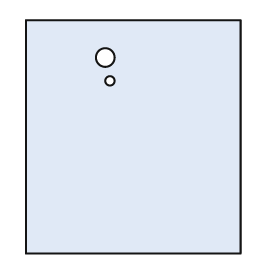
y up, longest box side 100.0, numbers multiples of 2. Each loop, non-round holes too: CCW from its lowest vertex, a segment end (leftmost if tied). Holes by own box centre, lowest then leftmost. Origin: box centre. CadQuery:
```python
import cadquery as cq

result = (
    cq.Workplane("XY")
    .moveTo(-46.0, -50.0)
    .lineTo(46.0, -50.0)
    .lineTo(46.0, 50.0)
    .lineTo(-46.0, 50.0)
    .close()
    .moveTo(-10.0, 24.0)
    .circle(2.0)
    .moveTo(-12.0, 34.0)
    .circle(4.0)
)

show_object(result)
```